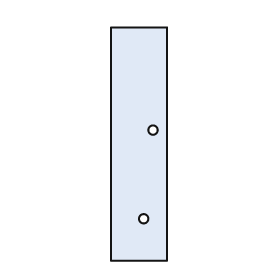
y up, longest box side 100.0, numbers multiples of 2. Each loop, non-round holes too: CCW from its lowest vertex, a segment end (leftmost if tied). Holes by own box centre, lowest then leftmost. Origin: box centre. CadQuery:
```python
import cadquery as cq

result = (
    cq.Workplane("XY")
    .moveTo(-12.0, -50.0)
    .lineTo(12.0, -50.0)
    .lineTo(12.0, 50.0)
    .lineTo(-12.0, 50.0)
    .close()
    .moveTo(2.0, -32.0)
    .circle(2.0)
    .moveTo(6.0, 6.0)
    .circle(2.0)
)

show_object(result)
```